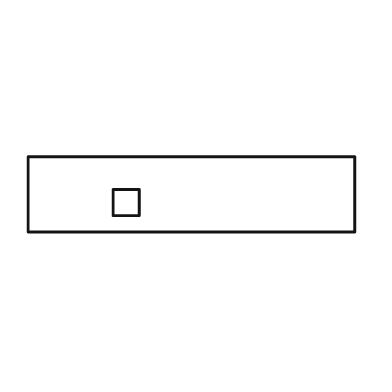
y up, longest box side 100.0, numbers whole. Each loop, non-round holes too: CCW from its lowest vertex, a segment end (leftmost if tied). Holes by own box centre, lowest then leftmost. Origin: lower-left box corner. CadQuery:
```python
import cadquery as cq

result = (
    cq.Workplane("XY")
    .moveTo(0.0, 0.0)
    .lineTo(100.0, 0.0)
    .lineTo(100.0, 23.0)
    .lineTo(0.0, 23.0)
    .close()
    .moveTo(26.0, 5.0)
    .lineTo(34.0, 5.0)
    .lineTo(34.0, 13.0)
    .lineTo(26.0, 13.0)
    .close()
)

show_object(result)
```